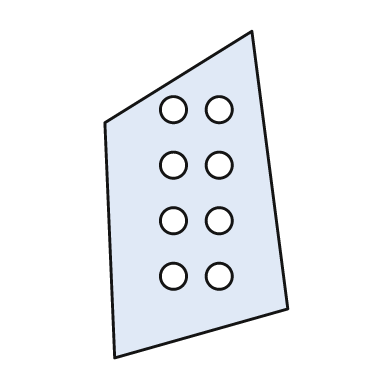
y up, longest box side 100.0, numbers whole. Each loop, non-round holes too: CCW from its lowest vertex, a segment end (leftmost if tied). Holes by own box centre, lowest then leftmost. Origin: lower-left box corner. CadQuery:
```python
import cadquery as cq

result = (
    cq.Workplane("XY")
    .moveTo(3.0, 0.0)
    .lineTo(56.0, 15.0)
    .lineTo(45.0, 100.0)
    .lineTo(0.0, 72.0)
    .close()
    .moveTo(21.0, 25.0)
    .circle(4.0)
    .moveTo(35.0, 25.0)
    .circle(4.0)
    .moveTo(21.0, 42.0)
    .circle(4.0)
    .moveTo(35.0, 42.0)
    .circle(4.0)
    .moveTo(21.0, 59.0)
    .circle(4.0)
    .moveTo(35.0, 59.0)
    .circle(4.0)
    .moveTo(21.0, 76.0)
    .circle(4.0)
    .moveTo(35.0, 76.0)
    .circle(4.0)
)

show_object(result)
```